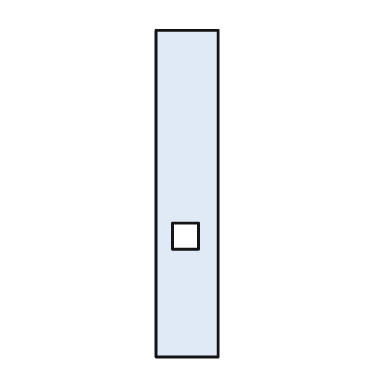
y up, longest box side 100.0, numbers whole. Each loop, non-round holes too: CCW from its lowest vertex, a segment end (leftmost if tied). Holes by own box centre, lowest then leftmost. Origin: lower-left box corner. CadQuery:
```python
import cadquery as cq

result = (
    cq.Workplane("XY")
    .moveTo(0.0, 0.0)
    .lineTo(19.0, 0.0)
    .lineTo(19.0, 100.0)
    .lineTo(0.0, 100.0)
    .close()
    .moveTo(5.0, 33.0)
    .lineTo(13.0, 33.0)
    .lineTo(13.0, 41.0)
    .lineTo(5.0, 41.0)
    .close()
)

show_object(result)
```